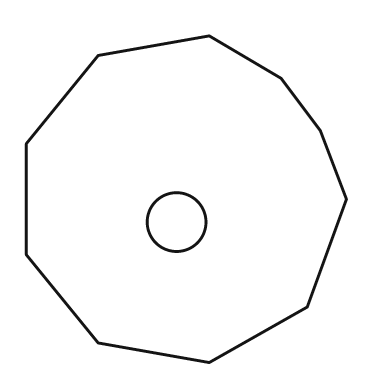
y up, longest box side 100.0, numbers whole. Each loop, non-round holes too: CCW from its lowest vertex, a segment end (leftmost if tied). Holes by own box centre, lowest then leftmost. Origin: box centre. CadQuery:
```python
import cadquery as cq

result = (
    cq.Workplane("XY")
    .moveTo(7.0, -50.0)
    .lineTo(37.0, -33.0)
    .lineTo(49.0, 0.0)
    .lineTo(41.0, 21.0)
    .lineTo(29.0, 37.0)
    .lineTo(7.0, 50.0)
    .lineTo(-27.0, 44.0)
    .lineTo(-49.0, 17.0)
    .lineTo(-49.0, -17.0)
    .lineTo(-27.0, -44.0)
    .close()
    .moveTo(-3.0, -7.0)
    .circle(9.0)
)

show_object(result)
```